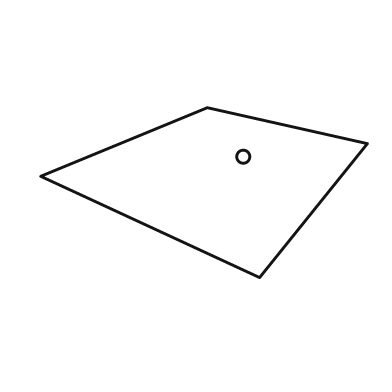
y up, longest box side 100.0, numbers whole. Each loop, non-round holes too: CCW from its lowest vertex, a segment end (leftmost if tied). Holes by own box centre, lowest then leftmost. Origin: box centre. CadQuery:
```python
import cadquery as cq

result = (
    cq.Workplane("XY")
    .moveTo(17.0, -26.0)
    .lineTo(50.0, 15.0)
    .lineTo(1.0, 26.0)
    .lineTo(-50.0, 5.0)
    .close()
    .moveTo(12.0, 11.0)
    .circle(2.0)
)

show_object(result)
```